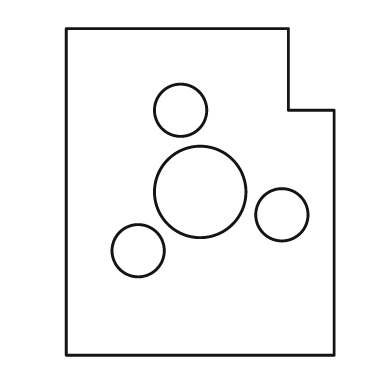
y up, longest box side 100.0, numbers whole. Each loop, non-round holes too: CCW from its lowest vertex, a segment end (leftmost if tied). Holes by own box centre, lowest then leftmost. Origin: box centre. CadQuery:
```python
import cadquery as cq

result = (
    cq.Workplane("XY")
    .moveTo(-41.0, -50.0)
    .lineTo(41.0, -50.0)
    .lineTo(41.0, 25.0)
    .lineTo(27.0, 25.0)
    .lineTo(27.0, 50.0)
    .lineTo(-41.0, 50.0)
    .close()
    .moveTo(-19.0, -18.0)
    .circle(8.0)
    .moveTo(25.0, -7.0)
    .circle(8.0)
    .moveTo(0.0, 0.0)
    .circle(14.0)
    .moveTo(-6.0, 25.0)
    .circle(8.0)
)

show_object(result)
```